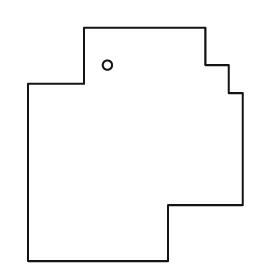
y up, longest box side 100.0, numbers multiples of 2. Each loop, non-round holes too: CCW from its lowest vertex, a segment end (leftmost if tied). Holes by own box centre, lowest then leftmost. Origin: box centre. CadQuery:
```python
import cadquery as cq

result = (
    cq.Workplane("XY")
    .moveTo(-46.0, -50.0)
    .lineTo(14.0, -50.0)
    .lineTo(14.0, -26.0)
    .lineTo(46.0, -26.0)
    .lineTo(46.0, 22.0)
    .lineTo(40.0, 22.0)
    .lineTo(40.0, 34.0)
    .lineTo(30.0, 34.0)
    .lineTo(30.0, 50.0)
    .lineTo(-22.0, 50.0)
    .lineTo(-22.0, 26.0)
    .lineTo(-46.0, 26.0)
    .close()
    .moveTo(-12.0, 34.0)
    .circle(2.0)
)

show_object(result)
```